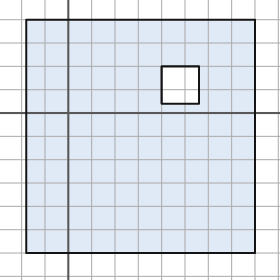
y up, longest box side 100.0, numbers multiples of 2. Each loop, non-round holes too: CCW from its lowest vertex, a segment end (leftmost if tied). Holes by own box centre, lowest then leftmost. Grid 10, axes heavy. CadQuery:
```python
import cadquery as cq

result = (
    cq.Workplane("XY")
    .moveTo(-18.0, -60.0)
    .lineTo(80.0, -60.0)
    .lineTo(80.0, 40.0)
    .lineTo(-18.0, 40.0)
    .close()
    .moveTo(40.0, 4.0)
    .lineTo(56.0, 4.0)
    .lineTo(56.0, 20.0)
    .lineTo(40.0, 20.0)
    .close()
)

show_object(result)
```